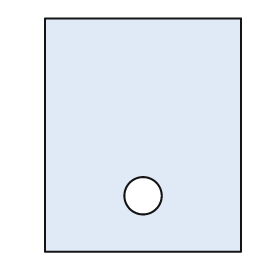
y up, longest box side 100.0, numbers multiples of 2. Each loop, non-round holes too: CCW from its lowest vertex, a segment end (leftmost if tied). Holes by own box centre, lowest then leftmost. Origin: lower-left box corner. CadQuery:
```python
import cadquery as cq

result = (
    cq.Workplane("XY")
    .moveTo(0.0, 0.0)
    .lineTo(84.0, 0.0)
    .lineTo(84.0, 100.0)
    .lineTo(0.0, 100.0)
    .close()
    .moveTo(42.0, 24.0)
    .circle(8.0)
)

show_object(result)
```